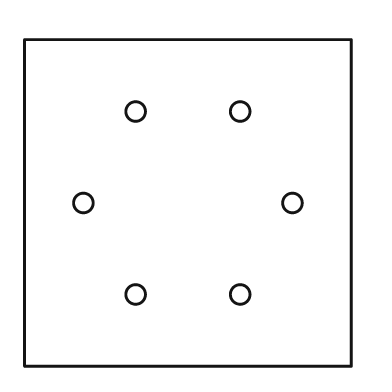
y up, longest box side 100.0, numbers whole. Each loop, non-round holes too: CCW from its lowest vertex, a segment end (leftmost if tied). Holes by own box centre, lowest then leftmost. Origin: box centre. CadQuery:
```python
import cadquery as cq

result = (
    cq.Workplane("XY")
    .moveTo(-50.0, -50.0)
    .lineTo(50.0, -50.0)
    .lineTo(50.0, 50.0)
    .lineTo(-50.0, 50.0)
    .close()
    .moveTo(-16.0, -28.0)
    .circle(3.0)
    .moveTo(16.0, -28.0)
    .circle(3.0)
    .moveTo(-32.0, 0.0)
    .circle(3.0)
    .moveTo(32.0, 0.0)
    .circle(3.0)
    .moveTo(-16.0, 28.0)
    .circle(3.0)
    .moveTo(16.0, 28.0)
    .circle(3.0)
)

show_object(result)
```